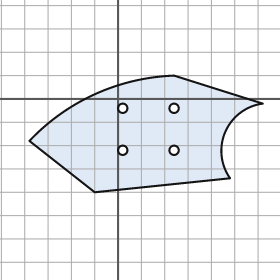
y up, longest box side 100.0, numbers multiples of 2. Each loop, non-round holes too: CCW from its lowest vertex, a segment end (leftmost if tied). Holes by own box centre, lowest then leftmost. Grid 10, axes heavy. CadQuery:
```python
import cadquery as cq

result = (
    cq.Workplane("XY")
    .moveTo(-10.0, -40.0)
    .lineTo(48.0, -34.0)
    .threePointArc((46.0, -14.0), (62.0, -2.0))
    .lineTo(24.0, 10.0)
    .threePointArc((-10.0, 2.0), (-38.0, -18.0))
    .close()
    .moveTo(2.0, -22.0)
    .circle(2.0)
    .moveTo(24.0, -22.0)
    .circle(2.0)
    .moveTo(2.0, -4.0)
    .circle(2.0)
    .moveTo(24.0, -4.0)
    .circle(2.0)
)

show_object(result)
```